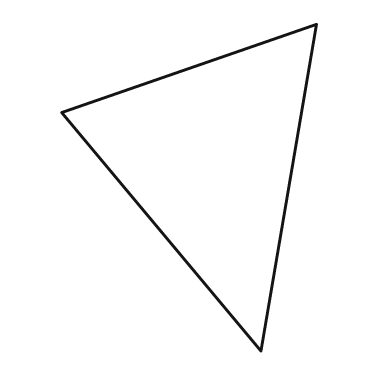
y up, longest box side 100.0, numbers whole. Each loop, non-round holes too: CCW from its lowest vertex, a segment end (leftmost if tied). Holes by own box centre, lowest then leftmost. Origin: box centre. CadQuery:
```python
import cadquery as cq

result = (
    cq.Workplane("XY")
    .moveTo(22.0, -50.0)
    .lineTo(39.0, 50.0)
    .lineTo(-39.0, 23.0)
    .close()
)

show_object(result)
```